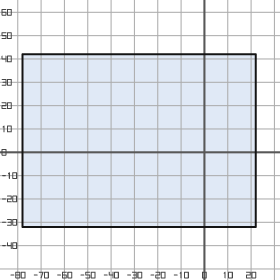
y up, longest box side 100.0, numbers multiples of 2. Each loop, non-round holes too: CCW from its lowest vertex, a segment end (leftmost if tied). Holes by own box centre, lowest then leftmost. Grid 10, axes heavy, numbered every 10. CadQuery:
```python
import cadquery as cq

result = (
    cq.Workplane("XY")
    .moveTo(-78.0, -32.0)
    .lineTo(22.0, -32.0)
    .lineTo(22.0, 42.0)
    .lineTo(-78.0, 42.0)
    .close()
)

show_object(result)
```